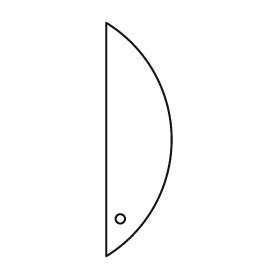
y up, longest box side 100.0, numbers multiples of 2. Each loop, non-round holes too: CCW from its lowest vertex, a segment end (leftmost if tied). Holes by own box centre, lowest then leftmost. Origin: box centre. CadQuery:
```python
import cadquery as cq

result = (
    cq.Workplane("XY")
    .moveTo(-14.0, -50.0)
    .threePointArc((14.0, 0.0), (-14.0, 50.0))
    .close()
    .moveTo(-8.0, -34.0)
    .circle(2.0)
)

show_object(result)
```